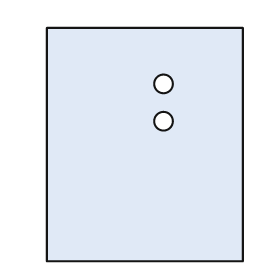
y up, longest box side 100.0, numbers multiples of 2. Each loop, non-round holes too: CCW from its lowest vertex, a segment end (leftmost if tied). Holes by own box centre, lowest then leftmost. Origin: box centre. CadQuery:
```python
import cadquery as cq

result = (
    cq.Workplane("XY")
    .moveTo(-42.0, -50.0)
    .lineTo(42.0, -50.0)
    .lineTo(42.0, 50.0)
    .lineTo(-42.0, 50.0)
    .close()
    .moveTo(8.0, 10.0)
    .circle(4.0)
    .moveTo(8.0, 26.0)
    .circle(4.0)
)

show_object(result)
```